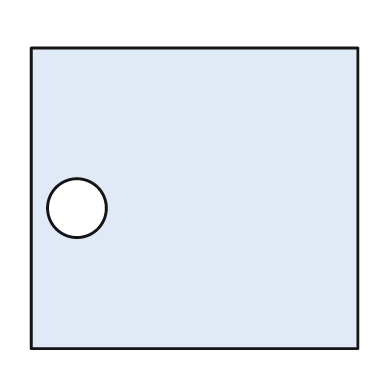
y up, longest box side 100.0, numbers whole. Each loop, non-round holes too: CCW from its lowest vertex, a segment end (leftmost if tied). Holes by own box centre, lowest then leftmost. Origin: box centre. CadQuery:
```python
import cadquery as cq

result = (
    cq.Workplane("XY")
    .moveTo(-50.0, -46.0)
    .lineTo(50.0, -46.0)
    .lineTo(50.0, 46.0)
    .lineTo(-50.0, 46.0)
    .close()
    .moveTo(-36.0, -3.0)
    .circle(9.0)
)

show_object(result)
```